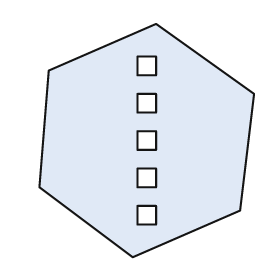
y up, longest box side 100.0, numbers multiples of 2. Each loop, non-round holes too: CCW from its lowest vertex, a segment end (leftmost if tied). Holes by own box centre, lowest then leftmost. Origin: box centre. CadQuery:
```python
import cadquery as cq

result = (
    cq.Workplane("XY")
    .moveTo(-6.0, -50.0)
    .lineTo(40.0, -30.0)
    .lineTo(46.0, 20.0)
    .lineTo(4.0, 50.0)
    .lineTo(-42.0, 30.0)
    .lineTo(-46.0, -20.0)
    .close()
    .moveTo(-4.0, -36.0)
    .lineTo(4.0, -36.0)
    .lineTo(4.0, -28.0)
    .lineTo(-4.0, -28.0)
    .close()
    .moveTo(-4.0, -20.0)
    .lineTo(4.0, -20.0)
    .lineTo(4.0, -12.0)
    .lineTo(-4.0, -12.0)
    .close()
    .moveTo(-4.0, -4.0)
    .lineTo(4.0, -4.0)
    .lineTo(4.0, 4.0)
    .lineTo(-4.0, 4.0)
    .close()
    .moveTo(-4.0, 12.0)
    .lineTo(4.0, 12.0)
    .lineTo(4.0, 20.0)
    .lineTo(-4.0, 20.0)
    .close()
    .moveTo(-4.0, 28.0)
    .lineTo(4.0, 28.0)
    .lineTo(4.0, 36.0)
    .lineTo(-4.0, 36.0)
    .close()
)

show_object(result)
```